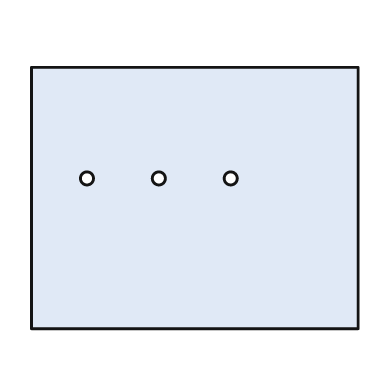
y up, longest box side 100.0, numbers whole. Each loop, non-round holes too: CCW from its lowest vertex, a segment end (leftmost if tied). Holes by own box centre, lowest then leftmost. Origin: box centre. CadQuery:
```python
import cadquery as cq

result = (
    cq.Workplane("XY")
    .moveTo(-50.0, -40.0)
    .lineTo(50.0, -40.0)
    .lineTo(50.0, 40.0)
    .lineTo(-50.0, 40.0)
    .close()
    .moveTo(-33.0, 6.0)
    .circle(2.0)
    .moveTo(-11.0, 6.0)
    .circle(2.0)
    .moveTo(11.0, 6.0)
    .circle(2.0)
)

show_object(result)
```